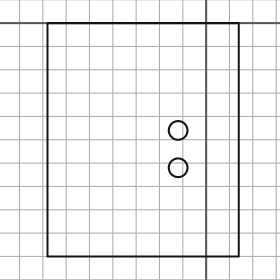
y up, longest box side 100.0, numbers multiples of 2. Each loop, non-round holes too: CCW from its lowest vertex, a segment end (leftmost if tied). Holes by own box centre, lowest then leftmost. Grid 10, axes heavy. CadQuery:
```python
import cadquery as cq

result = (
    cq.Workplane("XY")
    .moveTo(-68.0, -100.0)
    .lineTo(14.0, -100.0)
    .lineTo(14.0, 0.0)
    .lineTo(-68.0, 0.0)
    .close()
    .moveTo(-12.0, -62.0)
    .circle(4.0)
    .moveTo(-12.0, -46.0)
    .circle(4.0)
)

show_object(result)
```